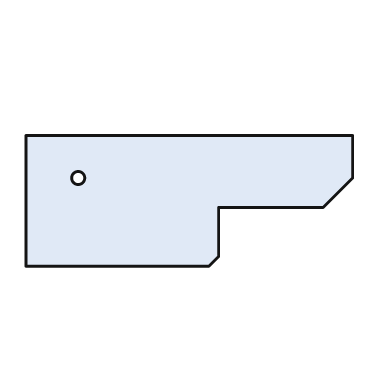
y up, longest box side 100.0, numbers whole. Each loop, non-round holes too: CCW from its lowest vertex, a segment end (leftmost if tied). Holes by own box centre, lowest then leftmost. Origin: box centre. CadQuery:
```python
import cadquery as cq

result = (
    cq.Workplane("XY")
    .moveTo(-50.0, -20.0)
    .lineTo(6.0, -20.0)
    .lineTo(9.0, -17.0)
    .lineTo(9.0, -2.0)
    .lineTo(41.0, -2.0)
    .lineTo(50.0, 7.0)
    .lineTo(50.0, 20.0)
    .lineTo(-50.0, 20.0)
    .close()
    .moveTo(-34.0, 7.0)
    .circle(2.0)
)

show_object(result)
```